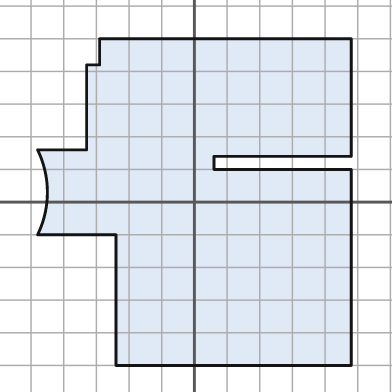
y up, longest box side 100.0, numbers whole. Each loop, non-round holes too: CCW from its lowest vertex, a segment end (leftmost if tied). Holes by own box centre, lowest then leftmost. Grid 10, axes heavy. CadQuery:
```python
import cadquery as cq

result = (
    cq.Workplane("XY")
    .moveTo(-24.0, -50.0)
    .lineTo(48.0, -50.0)
    .lineTo(48.0, 10.0)
    .lineTo(6.0, 10.0)
    .lineTo(6.0, 14.0)
    .lineTo(48.0, 14.0)
    .lineTo(48.0, 50.0)
    .lineTo(-29.0, 50.0)
    .lineTo(-29.0, 42.0)
    .lineTo(-33.0, 42.0)
    .lineTo(-33.0, 16.0)
    .lineTo(-48.0, 16.0)
    .threePointArc((-45.0, 3.0), (-48.0, -10.0))
    .lineTo(-24.0, -10.0)
    .close()
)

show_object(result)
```